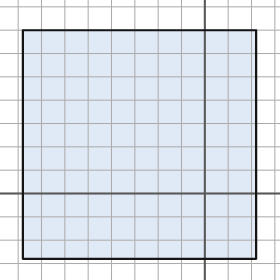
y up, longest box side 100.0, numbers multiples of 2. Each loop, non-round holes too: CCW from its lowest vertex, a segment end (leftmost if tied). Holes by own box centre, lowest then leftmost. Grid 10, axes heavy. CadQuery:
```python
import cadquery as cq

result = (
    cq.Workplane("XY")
    .moveTo(-78.0, -28.0)
    .lineTo(22.0, -28.0)
    .lineTo(22.0, 70.0)
    .lineTo(-78.0, 70.0)
    .close()
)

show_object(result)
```